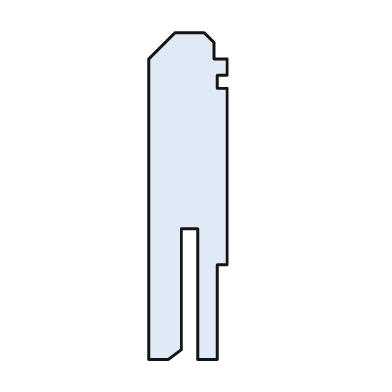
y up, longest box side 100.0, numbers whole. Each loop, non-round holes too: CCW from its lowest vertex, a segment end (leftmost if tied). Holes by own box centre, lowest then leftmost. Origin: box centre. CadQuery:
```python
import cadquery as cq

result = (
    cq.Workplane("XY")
    .moveTo(-12.0, -50.0)
    .lineTo(-6.0, -50.0)
    .lineTo(-2.0, -47.0)
    .lineTo(-2.0, -10.0)
    .lineTo(3.0, -10.0)
    .lineTo(3.0, -50.0)
    .lineTo(9.0, -50.0)
    .lineTo(9.0, -21.0)
    .lineTo(12.0, -21.0)
    .lineTo(12.0, 33.0)
    .lineTo(9.0, 33.0)
    .lineTo(9.0, 37.0)
    .lineTo(12.0, 37.0)
    .lineTo(12.0, 42.0)
    .lineTo(8.0, 42.0)
    .lineTo(8.0, 47.0)
    .lineTo(5.0, 50.0)
    .lineTo(-4.0, 50.0)
    .lineTo(-12.0, 42.0)
    .close()
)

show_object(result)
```